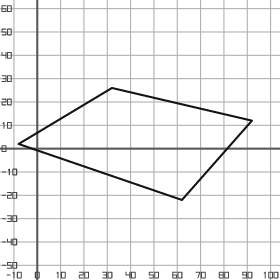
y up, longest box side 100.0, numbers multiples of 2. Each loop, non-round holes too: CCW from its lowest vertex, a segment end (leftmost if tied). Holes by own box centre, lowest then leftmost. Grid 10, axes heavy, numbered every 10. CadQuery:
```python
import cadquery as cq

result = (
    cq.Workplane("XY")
    .moveTo(62.0, -22.0)
    .lineTo(92.0, 12.0)
    .lineTo(32.0, 26.0)
    .lineTo(-8.0, 2.0)
    .close()
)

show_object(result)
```